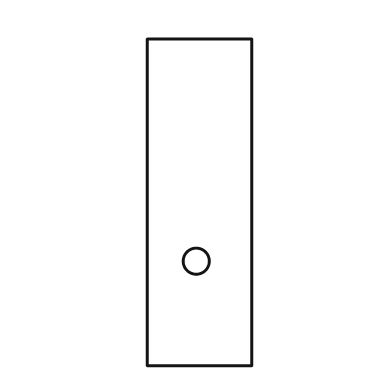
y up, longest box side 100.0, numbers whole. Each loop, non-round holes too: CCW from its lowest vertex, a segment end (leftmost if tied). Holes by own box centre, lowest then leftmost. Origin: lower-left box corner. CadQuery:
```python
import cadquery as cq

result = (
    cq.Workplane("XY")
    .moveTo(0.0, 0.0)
    .lineTo(32.0, 0.0)
    .lineTo(32.0, 100.0)
    .lineTo(0.0, 100.0)
    .close()
    .moveTo(15.0, 32.0)
    .circle(4.0)
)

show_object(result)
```